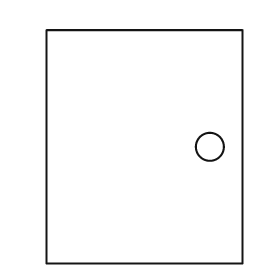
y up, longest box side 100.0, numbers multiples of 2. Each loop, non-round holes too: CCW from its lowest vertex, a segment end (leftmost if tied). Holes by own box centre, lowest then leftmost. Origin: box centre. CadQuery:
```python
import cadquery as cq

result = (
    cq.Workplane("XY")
    .moveTo(-42.0, -50.0)
    .lineTo(42.0, -50.0)
    .lineTo(42.0, 50.0)
    .lineTo(-42.0, 50.0)
    .close()
    .moveTo(28.0, 0.0)
    .circle(6.0)
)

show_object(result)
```